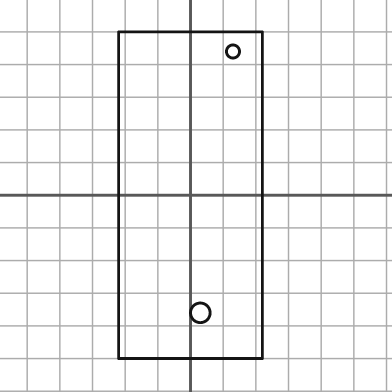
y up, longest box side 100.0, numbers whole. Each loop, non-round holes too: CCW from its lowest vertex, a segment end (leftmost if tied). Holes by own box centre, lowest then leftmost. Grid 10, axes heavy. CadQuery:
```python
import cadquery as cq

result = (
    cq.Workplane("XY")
    .moveTo(-22.0, -50.0)
    .lineTo(22.0, -50.0)
    .lineTo(22.0, 50.0)
    .lineTo(-22.0, 50.0)
    .close()
    .moveTo(3.0, -36.0)
    .circle(3.0)
    .moveTo(13.0, 44.0)
    .circle(2.0)
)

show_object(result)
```